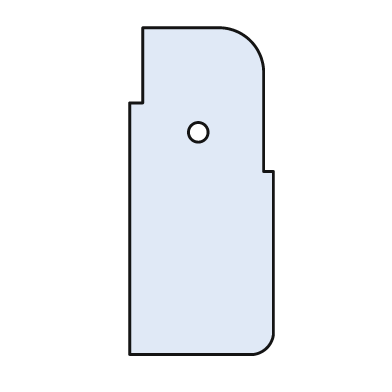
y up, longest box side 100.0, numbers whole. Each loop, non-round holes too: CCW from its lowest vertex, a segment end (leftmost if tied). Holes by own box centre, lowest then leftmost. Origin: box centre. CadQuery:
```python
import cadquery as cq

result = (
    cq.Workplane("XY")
    .moveTo(-22.0, -50.0)
    .lineTo(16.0, -50.0)
    .threePointArc((20.0, -48.0), (22.0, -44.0))
    .lineTo(22.0, 6.0)
    .lineTo(19.0, 6.0)
    .lineTo(19.0, 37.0)
    .threePointArc((15.0, 46.0), (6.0, 50.0))
    .lineTo(-18.0, 50.0)
    .lineTo(-18.0, 27.0)
    .lineTo(-22.0, 27.0)
    .close()
    .moveTo(-1.0, 18.0)
    .circle(3.0)
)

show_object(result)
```